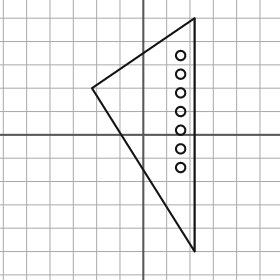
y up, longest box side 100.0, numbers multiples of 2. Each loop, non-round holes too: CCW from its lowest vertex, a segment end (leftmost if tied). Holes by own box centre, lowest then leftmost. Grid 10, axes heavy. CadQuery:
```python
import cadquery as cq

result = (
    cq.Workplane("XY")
    .moveTo(22.0, -50.0)
    .lineTo(22.0, 50.0)
    .lineTo(-22.0, 20.0)
    .close()
    .moveTo(16.0, -14.0)
    .circle(2.0)
    .moveTo(16.0, -6.0)
    .circle(2.0)
    .moveTo(16.0, 2.0)
    .circle(2.0)
    .moveTo(16.0, 10.0)
    .circle(2.0)
    .moveTo(16.0, 18.0)
    .circle(2.0)
    .moveTo(16.0, 26.0)
    .circle(2.0)
    .moveTo(16.0, 34.0)
    .circle(2.0)
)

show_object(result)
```